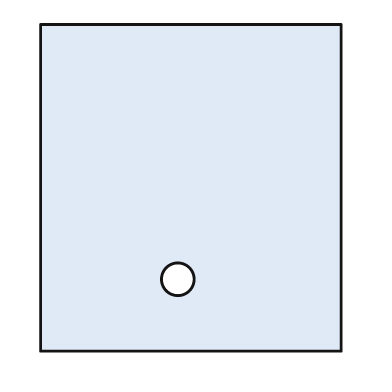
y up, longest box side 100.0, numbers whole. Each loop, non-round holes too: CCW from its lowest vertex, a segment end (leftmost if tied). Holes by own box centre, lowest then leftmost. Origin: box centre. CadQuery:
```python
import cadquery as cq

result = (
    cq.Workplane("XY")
    .moveTo(-46.0, -50.0)
    .lineTo(46.0, -50.0)
    .lineTo(46.0, 50.0)
    .lineTo(-46.0, 50.0)
    .close()
    .moveTo(-4.0, -28.0)
    .circle(5.0)
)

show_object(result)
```